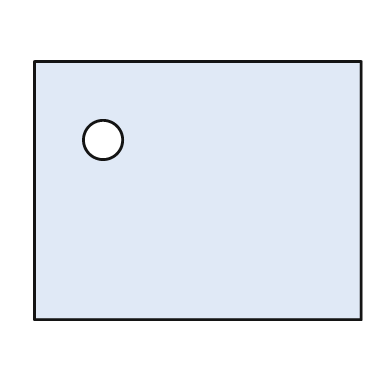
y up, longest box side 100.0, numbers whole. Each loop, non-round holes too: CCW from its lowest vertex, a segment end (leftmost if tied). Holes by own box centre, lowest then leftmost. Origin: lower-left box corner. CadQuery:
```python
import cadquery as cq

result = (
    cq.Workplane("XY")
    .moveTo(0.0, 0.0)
    .lineTo(100.0, 0.0)
    .lineTo(100.0, 79.0)
    .lineTo(0.0, 79.0)
    .close()
    .moveTo(21.0, 55.0)
    .circle(6.0)
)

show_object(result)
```